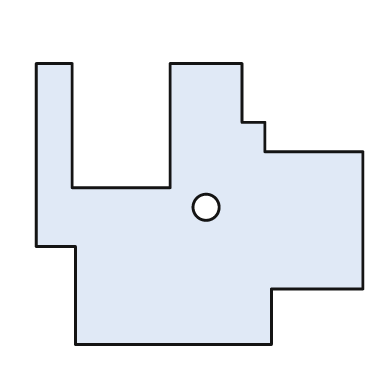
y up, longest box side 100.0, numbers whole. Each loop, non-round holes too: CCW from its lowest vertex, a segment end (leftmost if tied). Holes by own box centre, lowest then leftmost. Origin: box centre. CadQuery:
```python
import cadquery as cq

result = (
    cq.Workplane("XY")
    .moveTo(-38.0, -43.0)
    .lineTo(22.0, -43.0)
    .lineTo(22.0, -26.0)
    .lineTo(50.0, -26.0)
    .lineTo(50.0, 16.0)
    .lineTo(20.0, 16.0)
    .lineTo(20.0, 25.0)
    .lineTo(13.0, 25.0)
    .lineTo(13.0, 43.0)
    .lineTo(-9.0, 43.0)
    .lineTo(-9.0, 5.0)
    .lineTo(-39.0, 5.0)
    .lineTo(-39.0, 43.0)
    .lineTo(-50.0, 43.0)
    .lineTo(-50.0, -13.0)
    .lineTo(-38.0, -13.0)
    .close()
    .moveTo(2.0, -1.0)
    .circle(4.0)
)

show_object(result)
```